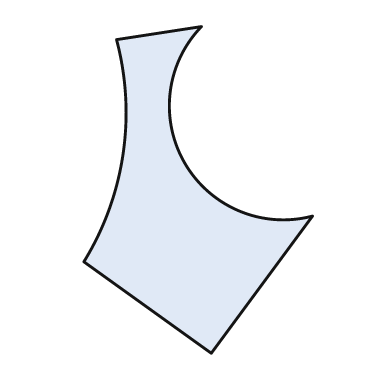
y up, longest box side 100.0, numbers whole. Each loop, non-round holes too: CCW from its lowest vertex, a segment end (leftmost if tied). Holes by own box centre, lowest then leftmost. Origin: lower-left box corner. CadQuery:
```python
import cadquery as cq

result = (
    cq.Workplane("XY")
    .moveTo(39.0, 0.0)
    .lineTo(70.0, 42.0)
    .threePointArc((31.0, 58.0), (36.0, 100.0))
    .lineTo(10.0, 96.0)
    .threePointArc((12.0, 61.0), (0.0, 28.0))
    .close()
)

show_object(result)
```